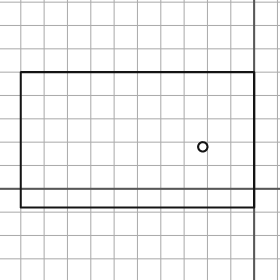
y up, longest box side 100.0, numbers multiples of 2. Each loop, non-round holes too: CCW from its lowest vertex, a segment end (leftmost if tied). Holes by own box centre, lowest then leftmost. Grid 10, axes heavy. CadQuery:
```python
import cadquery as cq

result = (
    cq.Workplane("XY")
    .moveTo(-100.0, -8.0)
    .lineTo(0.0, -8.0)
    .lineTo(0.0, 50.0)
    .lineTo(-100.0, 50.0)
    .close()
    .moveTo(-22.0, 18.0)
    .circle(2.0)
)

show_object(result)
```